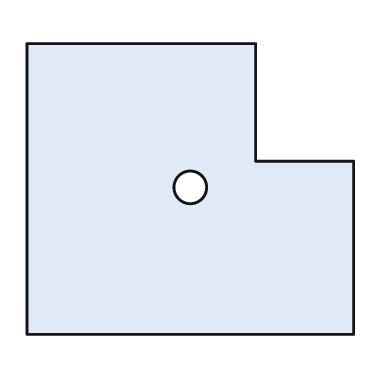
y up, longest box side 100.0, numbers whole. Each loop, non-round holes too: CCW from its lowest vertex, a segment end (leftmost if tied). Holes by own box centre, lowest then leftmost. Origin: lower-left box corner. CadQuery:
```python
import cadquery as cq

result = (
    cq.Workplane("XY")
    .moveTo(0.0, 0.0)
    .lineTo(100.0, 0.0)
    .lineTo(100.0, 53.0)
    .lineTo(70.0, 53.0)
    .lineTo(70.0, 89.0)
    .lineTo(0.0, 89.0)
    .close()
    .moveTo(50.0, 45.0)
    .circle(5.0)
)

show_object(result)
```